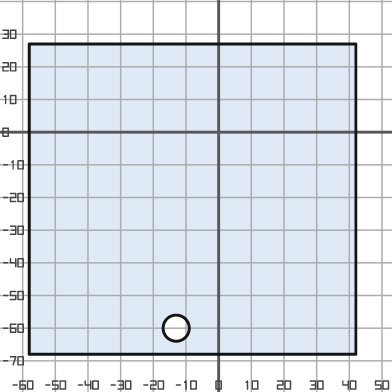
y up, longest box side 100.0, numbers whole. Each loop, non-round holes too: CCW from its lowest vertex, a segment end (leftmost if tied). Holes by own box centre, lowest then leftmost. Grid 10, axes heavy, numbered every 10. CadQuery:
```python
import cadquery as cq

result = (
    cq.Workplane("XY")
    .moveTo(-58.0, -68.0)
    .lineTo(42.0, -68.0)
    .lineTo(42.0, 27.0)
    .lineTo(-58.0, 27.0)
    .close()
    .moveTo(-13.0, -60.0)
    .circle(4.0)
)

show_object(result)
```